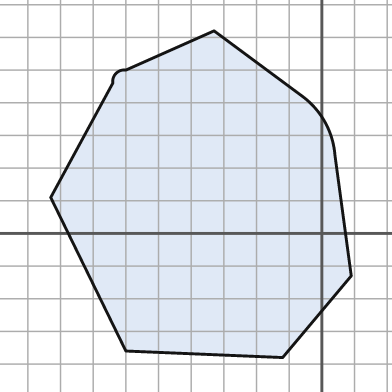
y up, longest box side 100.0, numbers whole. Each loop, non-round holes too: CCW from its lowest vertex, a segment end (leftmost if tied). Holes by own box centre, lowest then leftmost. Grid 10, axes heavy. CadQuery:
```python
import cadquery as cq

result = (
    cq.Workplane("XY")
    .moveTo(-12.0, -38.0)
    .lineTo(9.0, -13.0)
    .lineTo(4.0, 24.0)
    .threePointArc((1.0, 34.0), (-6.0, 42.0))
    .lineTo(-33.0, 62.0)
    .lineTo(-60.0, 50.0)
    .threePointArc((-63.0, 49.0), (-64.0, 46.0))
    .lineTo(-83.0, 11.0)
    .lineTo(-60.0, -36.0)
    .close()
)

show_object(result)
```